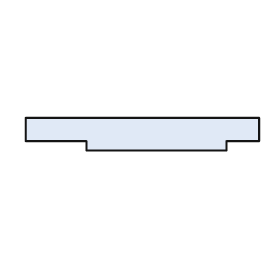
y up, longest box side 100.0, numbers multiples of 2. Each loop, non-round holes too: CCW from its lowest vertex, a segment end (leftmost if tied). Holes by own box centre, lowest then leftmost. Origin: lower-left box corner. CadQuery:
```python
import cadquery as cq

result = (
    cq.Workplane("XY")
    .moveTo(26.0, 0.0)
    .lineTo(86.0, 0.0)
    .lineTo(86.0, 4.0)
    .lineTo(100.0, 4.0)
    .lineTo(100.0, 14.0)
    .lineTo(0.0, 14.0)
    .lineTo(0.0, 4.0)
    .lineTo(26.0, 4.0)
    .close()
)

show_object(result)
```